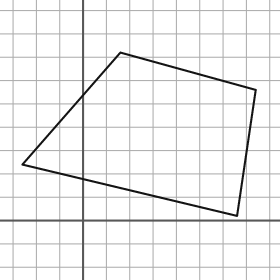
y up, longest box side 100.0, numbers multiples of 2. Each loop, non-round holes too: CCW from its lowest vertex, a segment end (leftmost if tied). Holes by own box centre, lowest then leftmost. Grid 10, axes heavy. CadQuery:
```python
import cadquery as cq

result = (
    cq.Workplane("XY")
    .moveTo(66.0, 2.0)
    .lineTo(74.0, 56.0)
    .lineTo(16.0, 72.0)
    .lineTo(-26.0, 24.0)
    .close()
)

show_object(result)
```